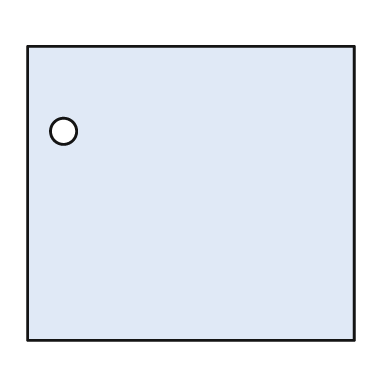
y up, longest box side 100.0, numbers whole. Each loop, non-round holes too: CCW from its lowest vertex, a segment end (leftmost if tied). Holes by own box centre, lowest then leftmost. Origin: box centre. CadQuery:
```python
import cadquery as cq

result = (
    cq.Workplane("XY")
    .moveTo(-50.0, -45.0)
    .lineTo(50.0, -45.0)
    .lineTo(50.0, 45.0)
    .lineTo(-50.0, 45.0)
    .close()
    .moveTo(-39.0, 19.0)
    .circle(4.0)
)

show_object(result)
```